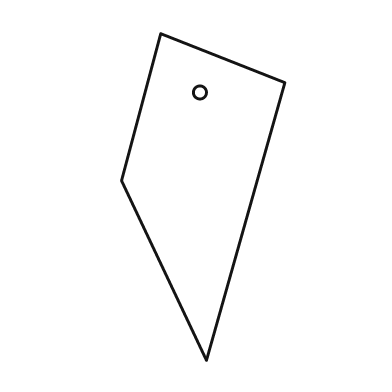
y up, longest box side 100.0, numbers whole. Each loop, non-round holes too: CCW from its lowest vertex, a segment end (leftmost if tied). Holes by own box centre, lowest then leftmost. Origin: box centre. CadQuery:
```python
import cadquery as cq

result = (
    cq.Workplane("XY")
    .moveTo(1.0, -50.0)
    .lineTo(25.0, 35.0)
    .lineTo(-13.0, 50.0)
    .lineTo(-25.0, 5.0)
    .close()
    .moveTo(-1.0, 32.0)
    .circle(2.0)
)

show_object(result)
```